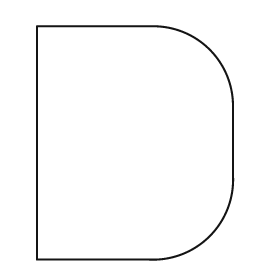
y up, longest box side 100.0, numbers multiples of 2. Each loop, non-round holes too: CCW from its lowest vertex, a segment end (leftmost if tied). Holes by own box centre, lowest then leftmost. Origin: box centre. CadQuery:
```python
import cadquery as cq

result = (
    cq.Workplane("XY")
    .moveTo(-42.0, -50.0)
    .lineTo(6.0, -50.0)
    .threePointArc((32.0, -40.0), (42.0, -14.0))
    .lineTo(42.0, 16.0)
    .threePointArc((32.0, 40.0), (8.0, 50.0))
    .lineTo(-42.0, 50.0)
    .close()
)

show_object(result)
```